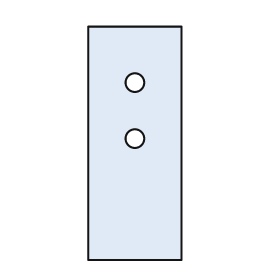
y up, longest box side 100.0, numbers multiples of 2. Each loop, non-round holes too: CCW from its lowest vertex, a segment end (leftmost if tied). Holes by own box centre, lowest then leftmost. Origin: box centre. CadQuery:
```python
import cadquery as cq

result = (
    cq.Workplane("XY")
    .moveTo(-20.0, -50.0)
    .lineTo(20.0, -50.0)
    .lineTo(20.0, 50.0)
    .lineTo(-20.0, 50.0)
    .close()
    .moveTo(0.0, 2.0)
    .circle(4.0)
    .moveTo(0.0, 26.0)
    .circle(4.0)
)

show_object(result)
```